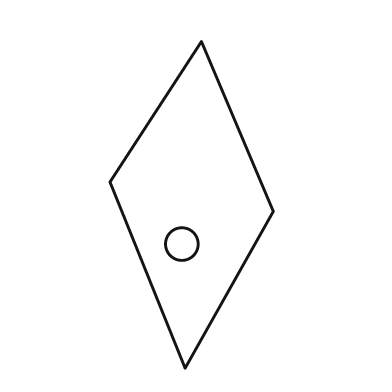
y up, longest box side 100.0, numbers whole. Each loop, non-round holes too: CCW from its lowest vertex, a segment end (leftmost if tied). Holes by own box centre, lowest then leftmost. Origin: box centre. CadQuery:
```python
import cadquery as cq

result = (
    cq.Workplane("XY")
    .moveTo(-2.0, -50.0)
    .lineTo(25.0, -2.0)
    .lineTo(3.0, 50.0)
    .lineTo(-25.0, 7.0)
    .close()
    .moveTo(-3.0, -12.0)
    .circle(5.0)
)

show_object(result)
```